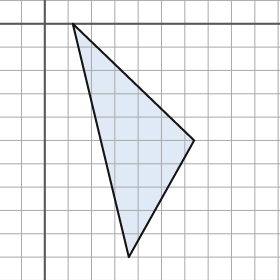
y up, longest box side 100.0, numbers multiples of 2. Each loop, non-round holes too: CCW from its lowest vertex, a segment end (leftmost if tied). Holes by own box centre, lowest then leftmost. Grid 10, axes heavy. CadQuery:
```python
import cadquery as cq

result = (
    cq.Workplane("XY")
    .moveTo(36.0, -100.0)
    .lineTo(64.0, -50.0)
    .lineTo(12.0, 0.0)
    .close()
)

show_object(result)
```